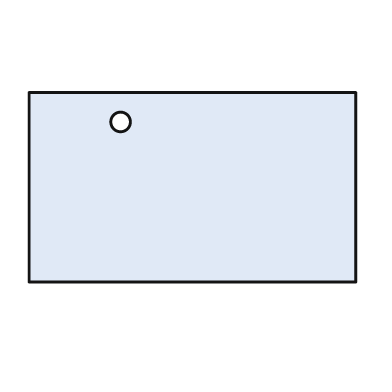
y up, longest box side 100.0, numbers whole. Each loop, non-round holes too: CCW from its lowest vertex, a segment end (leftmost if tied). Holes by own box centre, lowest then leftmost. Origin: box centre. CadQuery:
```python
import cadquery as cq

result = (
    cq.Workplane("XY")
    .moveTo(-50.0, -29.0)
    .lineTo(50.0, -29.0)
    .lineTo(50.0, 29.0)
    .lineTo(-50.0, 29.0)
    .close()
    .moveTo(-22.0, 20.0)
    .circle(3.0)
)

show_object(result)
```